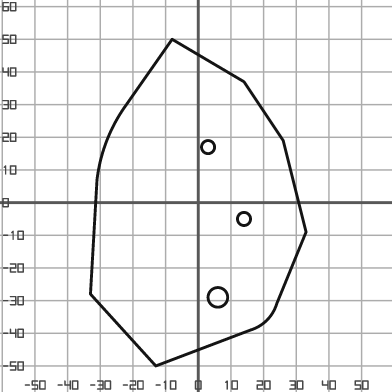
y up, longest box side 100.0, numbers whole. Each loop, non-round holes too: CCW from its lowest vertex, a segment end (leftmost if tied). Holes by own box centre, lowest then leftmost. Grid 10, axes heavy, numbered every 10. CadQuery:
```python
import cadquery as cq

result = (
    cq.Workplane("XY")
    .moveTo(-13.0, -50.0)
    .lineTo(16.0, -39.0)
    .threePointArc((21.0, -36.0), (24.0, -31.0))
    .lineTo(33.0, -9.0)
    .lineTo(26.0, 19.0)
    .lineTo(14.0, 37.0)
    .lineTo(-8.0, 50.0)
    .lineTo(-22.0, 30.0)
    .threePointArc((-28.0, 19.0), (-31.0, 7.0))
    .lineTo(-33.0, -28.0)
    .close()
    .moveTo(6.0, -29.0)
    .circle(3.0)
    .moveTo(14.0, -5.0)
    .circle(2.0)
    .moveTo(3.0, 17.0)
    .circle(2.0)
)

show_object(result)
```